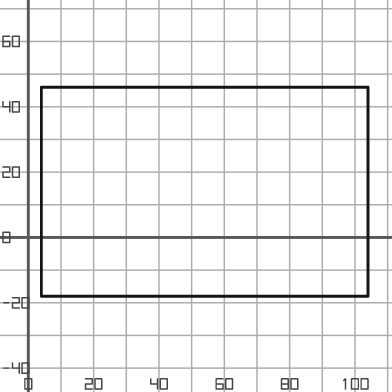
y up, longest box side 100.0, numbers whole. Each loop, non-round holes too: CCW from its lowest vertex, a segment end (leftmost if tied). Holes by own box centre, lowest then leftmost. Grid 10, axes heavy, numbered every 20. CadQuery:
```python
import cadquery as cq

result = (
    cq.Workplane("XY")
    .moveTo(4.0, -18.0)
    .lineTo(104.0, -18.0)
    .lineTo(104.0, 46.0)
    .lineTo(4.0, 46.0)
    .close()
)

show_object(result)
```